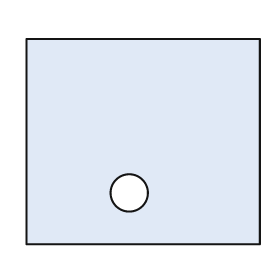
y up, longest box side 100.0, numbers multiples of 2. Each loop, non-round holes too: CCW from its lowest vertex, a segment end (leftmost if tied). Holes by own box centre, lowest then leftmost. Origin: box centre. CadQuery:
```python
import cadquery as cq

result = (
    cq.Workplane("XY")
    .moveTo(-50.0, -44.0)
    .lineTo(50.0, -44.0)
    .lineTo(50.0, 44.0)
    .lineTo(-50.0, 44.0)
    .close()
    .moveTo(-6.0, -22.0)
    .circle(8.0)
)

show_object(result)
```